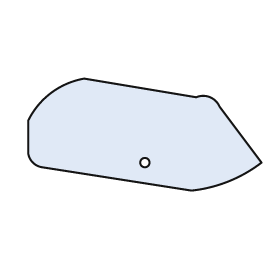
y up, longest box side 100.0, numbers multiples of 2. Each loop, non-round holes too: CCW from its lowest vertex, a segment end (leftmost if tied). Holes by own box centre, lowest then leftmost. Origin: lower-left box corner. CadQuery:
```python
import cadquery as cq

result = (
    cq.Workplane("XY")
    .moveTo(70.0, 0.0)
    .threePointArc((86.0, 4.0), (100.0, 12.0))
    .lineTo(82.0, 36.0)
    .threePointArc((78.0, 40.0), (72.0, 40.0))
    .lineTo(24.0, 48.0)
    .threePointArc((10.0, 42.0), (0.0, 30.0))
    .lineTo(0.0, 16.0)
    .threePointArc((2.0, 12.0), (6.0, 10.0))
    .close()
    .moveTo(50.0, 12.0)
    .circle(2.0)
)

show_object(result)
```